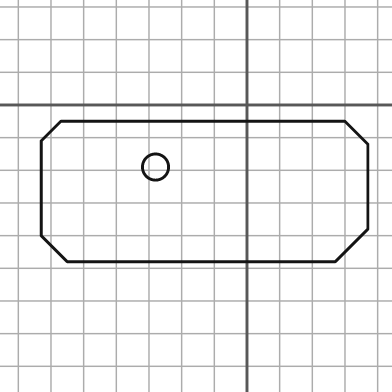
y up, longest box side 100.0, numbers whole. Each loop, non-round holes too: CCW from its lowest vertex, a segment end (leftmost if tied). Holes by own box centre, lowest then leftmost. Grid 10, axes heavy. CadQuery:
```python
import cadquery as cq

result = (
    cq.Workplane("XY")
    .moveTo(-55.0, -48.0)
    .lineTo(27.0, -48.0)
    .lineTo(37.0, -38.0)
    .lineTo(37.0, -12.0)
    .lineTo(30.0, -5.0)
    .lineTo(-57.0, -5.0)
    .lineTo(-63.0, -11.0)
    .lineTo(-63.0, -40.0)
    .close()
    .moveTo(-28.0, -19.0)
    .circle(4.0)
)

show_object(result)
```